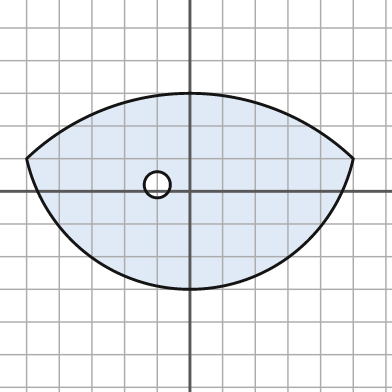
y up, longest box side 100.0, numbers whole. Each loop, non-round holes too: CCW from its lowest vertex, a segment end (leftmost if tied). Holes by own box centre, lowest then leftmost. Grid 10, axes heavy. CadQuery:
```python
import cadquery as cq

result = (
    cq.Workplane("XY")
    .moveTo(-50.0, 10.0)
    .threePointArc((0.0, -30.0), (50.0, 10.0))
    .threePointArc((0.0, 30.0), (-50.0, 10.0))
    .close()
    .moveTo(-10.0, 2.0)
    .circle(4.0)
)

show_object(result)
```